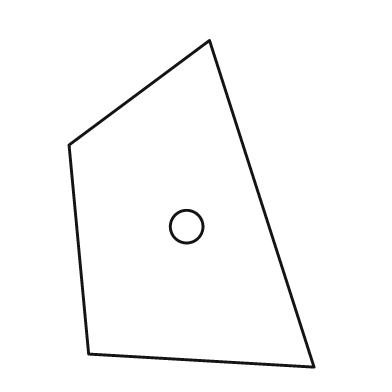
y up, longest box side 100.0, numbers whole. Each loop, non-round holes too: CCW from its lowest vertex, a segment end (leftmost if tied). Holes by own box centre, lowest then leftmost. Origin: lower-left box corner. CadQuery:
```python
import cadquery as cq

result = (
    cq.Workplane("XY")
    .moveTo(75.0, 0.0)
    .lineTo(43.0, 100.0)
    .lineTo(0.0, 68.0)
    .lineTo(6.0, 4.0)
    .close()
    .moveTo(36.0, 43.0)
    .circle(5.0)
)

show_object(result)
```